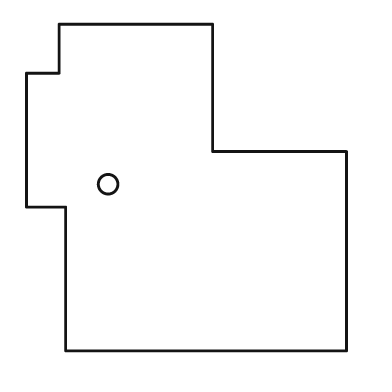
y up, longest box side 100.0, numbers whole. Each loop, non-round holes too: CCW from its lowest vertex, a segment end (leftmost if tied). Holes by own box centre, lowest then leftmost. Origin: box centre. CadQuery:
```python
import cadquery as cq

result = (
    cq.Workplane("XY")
    .moveTo(-37.0, -50.0)
    .lineTo(49.0, -50.0)
    .lineTo(49.0, 11.0)
    .lineTo(8.0, 11.0)
    .lineTo(8.0, 50.0)
    .lineTo(-39.0, 50.0)
    .lineTo(-39.0, 35.0)
    .lineTo(-49.0, 35.0)
    .lineTo(-49.0, -6.0)
    .lineTo(-37.0, -6.0)
    .close()
    .moveTo(-24.0, 1.0)
    .circle(3.0)
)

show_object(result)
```